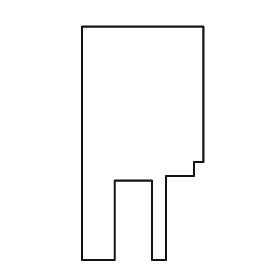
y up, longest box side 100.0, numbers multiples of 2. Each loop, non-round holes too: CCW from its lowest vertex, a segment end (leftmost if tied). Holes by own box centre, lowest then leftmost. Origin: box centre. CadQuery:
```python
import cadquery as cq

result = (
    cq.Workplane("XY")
    .moveTo(-26.0, -50.0)
    .lineTo(-12.0, -50.0)
    .lineTo(-12.0, -16.0)
    .lineTo(4.0, -16.0)
    .lineTo(4.0, -50.0)
    .lineTo(10.0, -50.0)
    .lineTo(10.0, -14.0)
    .lineTo(22.0, -14.0)
    .lineTo(22.0, -8.0)
    .lineTo(26.0, -8.0)
    .lineTo(26.0, 50.0)
    .lineTo(-26.0, 50.0)
    .close()
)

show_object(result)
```